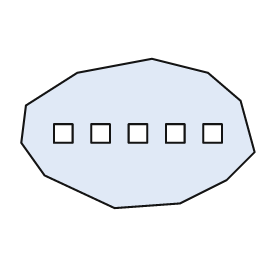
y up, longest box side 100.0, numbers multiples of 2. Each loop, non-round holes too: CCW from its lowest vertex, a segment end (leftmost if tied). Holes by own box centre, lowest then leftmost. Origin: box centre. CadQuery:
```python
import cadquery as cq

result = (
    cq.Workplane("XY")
    .moveTo(-10.0, -32.0)
    .lineTo(18.0, -30.0)
    .lineTo(38.0, -20.0)
    .lineTo(50.0, -8.0)
    .lineTo(44.0, 14.0)
    .lineTo(30.0, 26.0)
    .lineTo(6.0, 32.0)
    .lineTo(-26.0, 26.0)
    .lineTo(-48.0, 12.0)
    .lineTo(-50.0, -4.0)
    .lineTo(-40.0, -18.0)
    .close()
    .moveTo(-36.0, -4.0)
    .lineTo(-28.0, -4.0)
    .lineTo(-28.0, 4.0)
    .lineTo(-36.0, 4.0)
    .close()
    .moveTo(-20.0, -4.0)
    .lineTo(-12.0, -4.0)
    .lineTo(-12.0, 4.0)
    .lineTo(-20.0, 4.0)
    .close()
    .moveTo(-4.0, -4.0)
    .lineTo(4.0, -4.0)
    .lineTo(4.0, 4.0)
    .lineTo(-4.0, 4.0)
    .close()
    .moveTo(12.0, -4.0)
    .lineTo(20.0, -4.0)
    .lineTo(20.0, 4.0)
    .lineTo(12.0, 4.0)
    .close()
    .moveTo(28.0, -4.0)
    .lineTo(36.0, -4.0)
    .lineTo(36.0, 4.0)
    .lineTo(28.0, 4.0)
    .close()
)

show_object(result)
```